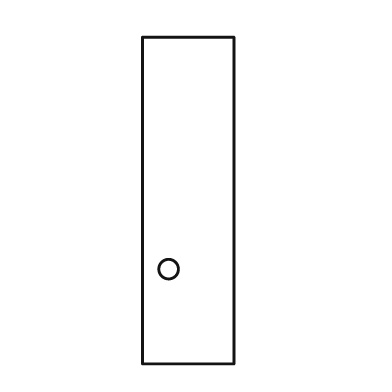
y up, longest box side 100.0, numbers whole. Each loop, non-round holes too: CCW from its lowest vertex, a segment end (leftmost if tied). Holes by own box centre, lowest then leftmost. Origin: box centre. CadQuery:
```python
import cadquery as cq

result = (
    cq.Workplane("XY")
    .moveTo(-14.0, -50.0)
    .lineTo(14.0, -50.0)
    .lineTo(14.0, 50.0)
    .lineTo(-14.0, 50.0)
    .close()
    .moveTo(-6.0, -21.0)
    .circle(3.0)
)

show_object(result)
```